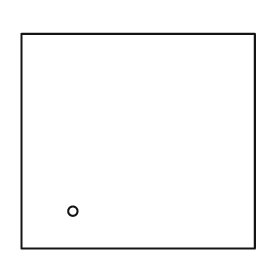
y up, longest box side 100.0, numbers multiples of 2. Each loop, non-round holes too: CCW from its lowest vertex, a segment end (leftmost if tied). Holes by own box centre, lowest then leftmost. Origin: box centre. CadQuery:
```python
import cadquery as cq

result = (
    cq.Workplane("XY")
    .moveTo(-50.0, -46.0)
    .lineTo(50.0, -46.0)
    .lineTo(50.0, 46.0)
    .lineTo(-50.0, 46.0)
    .close()
    .moveTo(-28.0, -30.0)
    .circle(2.0)
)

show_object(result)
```